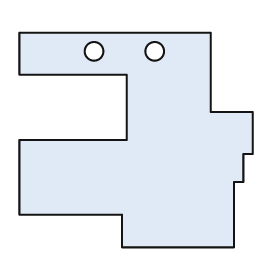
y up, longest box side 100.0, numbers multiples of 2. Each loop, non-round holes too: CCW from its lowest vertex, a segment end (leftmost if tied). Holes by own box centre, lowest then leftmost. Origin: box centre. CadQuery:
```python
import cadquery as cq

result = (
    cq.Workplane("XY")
    .moveTo(-6.0, -46.0)
    .lineTo(42.0, -46.0)
    .lineTo(42.0, -18.0)
    .lineTo(46.0, -18.0)
    .lineTo(46.0, -6.0)
    .lineTo(50.0, -6.0)
    .lineTo(50.0, 12.0)
    .lineTo(32.0, 12.0)
    .lineTo(32.0, 46.0)
    .lineTo(-50.0, 46.0)
    .lineTo(-50.0, 28.0)
    .lineTo(-4.0, 28.0)
    .lineTo(-4.0, 0.0)
    .lineTo(-50.0, 0.0)
    .lineTo(-50.0, -32.0)
    .lineTo(-6.0, -32.0)
    .close()
    .moveTo(-18.0, 38.0)
    .circle(4.0)
    .moveTo(8.0, 38.0)
    .circle(4.0)
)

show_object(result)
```